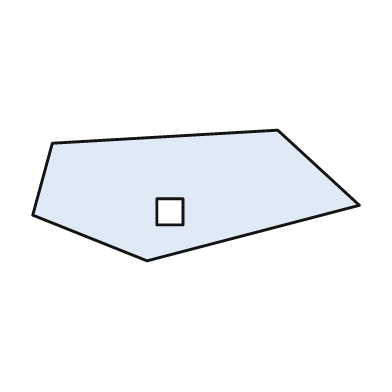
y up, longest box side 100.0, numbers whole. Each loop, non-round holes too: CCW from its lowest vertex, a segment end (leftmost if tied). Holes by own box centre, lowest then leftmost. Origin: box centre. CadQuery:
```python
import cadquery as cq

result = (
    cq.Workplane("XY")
    .moveTo(-15.0, -20.0)
    .lineTo(50.0, -3.0)
    .lineTo(25.0, 20.0)
    .lineTo(-44.0, 16.0)
    .lineTo(-50.0, -6.0)
    .close()
    .moveTo(-12.0, -9.0)
    .lineTo(-4.0, -9.0)
    .lineTo(-4.0, -1.0)
    .lineTo(-12.0, -1.0)
    .close()
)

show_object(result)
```